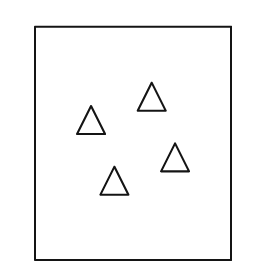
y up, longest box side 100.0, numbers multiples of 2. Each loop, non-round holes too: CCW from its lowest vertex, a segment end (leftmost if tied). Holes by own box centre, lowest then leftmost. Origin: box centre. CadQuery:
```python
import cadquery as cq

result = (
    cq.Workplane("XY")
    .moveTo(-42.0, -50.0)
    .lineTo(42.0, -50.0)
    .lineTo(42.0, 50.0)
    .lineTo(-42.0, 50.0)
    .close()
    .moveTo(-14.0, -22.0)
    .lineTo(-2.0, -22.0)
    .lineTo(-8.0, -10.0)
    .close()
    .moveTo(12.0, -12.0)
    .lineTo(24.0, -12.0)
    .lineTo(18.0, 0.0)
    .close()
    .moveTo(-24.0, 4.0)
    .lineTo(-12.0, 4.0)
    .lineTo(-18.0, 16.0)
    .close()
    .moveTo(2.0, 14.0)
    .lineTo(14.0, 14.0)
    .lineTo(8.0, 26.0)
    .close()
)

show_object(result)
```